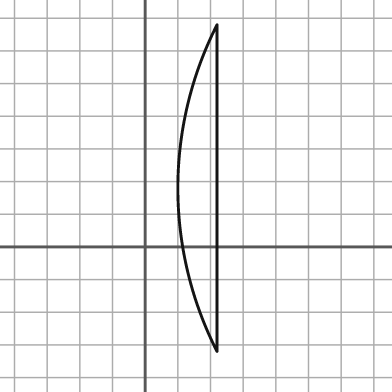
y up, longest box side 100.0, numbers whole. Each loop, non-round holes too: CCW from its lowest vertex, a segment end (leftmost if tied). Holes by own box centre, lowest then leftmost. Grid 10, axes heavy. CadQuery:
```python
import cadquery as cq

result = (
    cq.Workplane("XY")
    .moveTo(22.0, -32.0)
    .lineTo(22.0, 68.0)
    .threePointArc((10.0, 18.0), (22.0, -32.0))
    .close()
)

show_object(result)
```